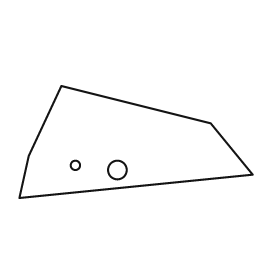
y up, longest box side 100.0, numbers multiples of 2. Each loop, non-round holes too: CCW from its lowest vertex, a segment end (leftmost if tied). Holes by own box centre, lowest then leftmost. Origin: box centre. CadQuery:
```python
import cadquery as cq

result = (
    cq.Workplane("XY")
    .moveTo(-50.0, -24.0)
    .lineTo(50.0, -14.0)
    .lineTo(32.0, 8.0)
    .lineTo(-32.0, 24.0)
    .lineTo(-46.0, -6.0)
    .close()
    .moveTo(-8.0, -12.0)
    .circle(4.0)
    .moveTo(-26.0, -10.0)
    .circle(2.0)
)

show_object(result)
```